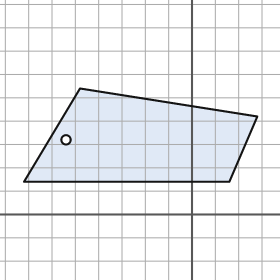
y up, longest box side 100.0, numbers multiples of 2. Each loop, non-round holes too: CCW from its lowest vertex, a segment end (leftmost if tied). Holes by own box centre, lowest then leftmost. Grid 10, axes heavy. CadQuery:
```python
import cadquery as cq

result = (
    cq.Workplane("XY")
    .moveTo(-72.0, 14.0)
    .lineTo(16.0, 14.0)
    .lineTo(28.0, 42.0)
    .lineTo(-48.0, 54.0)
    .close()
    .moveTo(-54.0, 32.0)
    .circle(2.0)
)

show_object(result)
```